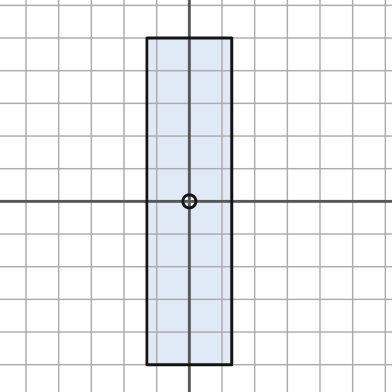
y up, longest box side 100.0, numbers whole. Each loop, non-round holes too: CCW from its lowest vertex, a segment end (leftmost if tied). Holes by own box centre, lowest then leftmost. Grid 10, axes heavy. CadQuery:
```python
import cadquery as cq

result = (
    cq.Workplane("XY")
    .moveTo(-13.0, -50.0)
    .lineTo(13.0, -50.0)
    .lineTo(13.0, 50.0)
    .lineTo(-13.0, 50.0)
    .close()
    .moveTo(0.0, 0.0)
    .circle(2.0)
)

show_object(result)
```